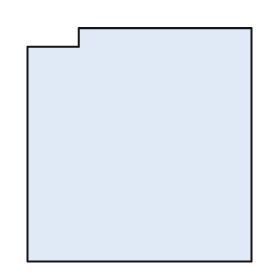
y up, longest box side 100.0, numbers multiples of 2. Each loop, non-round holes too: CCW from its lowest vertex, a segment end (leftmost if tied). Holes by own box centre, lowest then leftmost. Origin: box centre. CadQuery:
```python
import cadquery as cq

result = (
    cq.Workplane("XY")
    .moveTo(-48.0, -50.0)
    .lineTo(48.0, -50.0)
    .lineTo(48.0, 50.0)
    .lineTo(-26.0, 50.0)
    .lineTo(-26.0, 42.0)
    .lineTo(-48.0, 42.0)
    .close()
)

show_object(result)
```